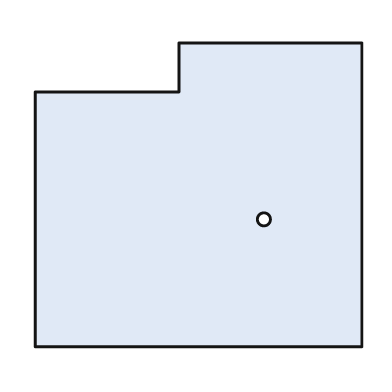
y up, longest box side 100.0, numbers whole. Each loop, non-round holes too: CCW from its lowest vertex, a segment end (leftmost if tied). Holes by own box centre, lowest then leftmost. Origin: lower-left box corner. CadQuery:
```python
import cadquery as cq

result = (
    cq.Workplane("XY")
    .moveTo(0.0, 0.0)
    .lineTo(100.0, 0.0)
    .lineTo(100.0, 93.0)
    .lineTo(44.0, 93.0)
    .lineTo(44.0, 78.0)
    .lineTo(0.0, 78.0)
    .close()
    .moveTo(70.0, 39.0)
    .circle(2.0)
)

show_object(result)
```